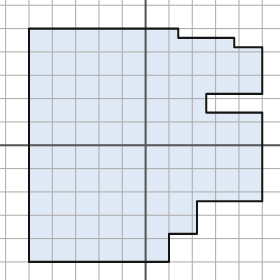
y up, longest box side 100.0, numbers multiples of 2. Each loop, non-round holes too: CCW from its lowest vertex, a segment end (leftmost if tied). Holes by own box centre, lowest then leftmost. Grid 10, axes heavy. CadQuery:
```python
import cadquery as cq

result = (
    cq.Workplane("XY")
    .moveTo(-50.0, -50.0)
    .lineTo(10.0, -50.0)
    .lineTo(10.0, -38.0)
    .lineTo(22.0, -38.0)
    .lineTo(22.0, -24.0)
    .lineTo(50.0, -24.0)
    .lineTo(50.0, 14.0)
    .lineTo(26.0, 14.0)
    .lineTo(26.0, 22.0)
    .lineTo(50.0, 22.0)
    .lineTo(50.0, 42.0)
    .lineTo(38.0, 42.0)
    .lineTo(38.0, 46.0)
    .lineTo(14.0, 46.0)
    .lineTo(14.0, 50.0)
    .lineTo(-50.0, 50.0)
    .close()
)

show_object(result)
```